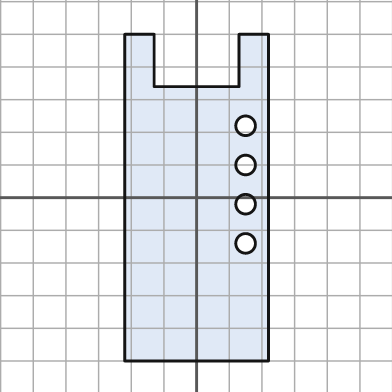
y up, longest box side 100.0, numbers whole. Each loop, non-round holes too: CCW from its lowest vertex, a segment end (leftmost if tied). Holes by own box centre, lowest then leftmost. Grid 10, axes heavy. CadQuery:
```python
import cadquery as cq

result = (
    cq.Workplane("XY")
    .moveTo(-22.0, -50.0)
    .lineTo(22.0, -50.0)
    .lineTo(22.0, 50.0)
    .lineTo(13.0, 50.0)
    .lineTo(13.0, 34.0)
    .lineTo(-13.0, 34.0)
    .lineTo(-13.0, 50.0)
    .lineTo(-22.0, 50.0)
    .close()
    .moveTo(15.0, -14.0)
    .circle(3.0)
    .moveTo(15.0, -2.0)
    .circle(3.0)
    .moveTo(15.0, 10.0)
    .circle(3.0)
    .moveTo(15.0, 22.0)
    .circle(3.0)
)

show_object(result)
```